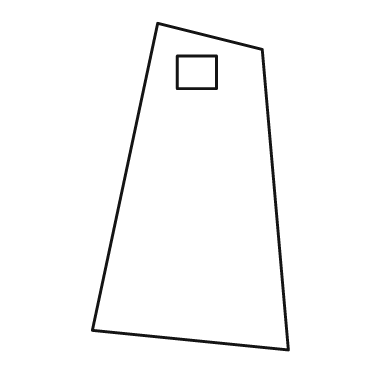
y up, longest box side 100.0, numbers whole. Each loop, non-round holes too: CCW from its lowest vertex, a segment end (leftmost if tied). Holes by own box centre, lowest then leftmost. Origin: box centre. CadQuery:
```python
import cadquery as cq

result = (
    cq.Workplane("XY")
    .moveTo(30.0, -50.0)
    .lineTo(22.0, 42.0)
    .lineTo(-10.0, 50.0)
    .lineTo(-30.0, -44.0)
    .close()
    .moveTo(-4.0, 30.0)
    .lineTo(8.0, 30.0)
    .lineTo(8.0, 40.0)
    .lineTo(-4.0, 40.0)
    .close()
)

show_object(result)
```